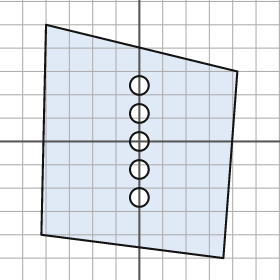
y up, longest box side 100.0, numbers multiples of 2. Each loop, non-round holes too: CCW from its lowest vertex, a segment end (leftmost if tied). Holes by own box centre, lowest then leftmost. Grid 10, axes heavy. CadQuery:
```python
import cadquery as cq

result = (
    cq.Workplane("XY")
    .moveTo(36.0, -50.0)
    .lineTo(42.0, 30.0)
    .lineTo(-40.0, 50.0)
    .lineTo(-42.0, -40.0)
    .close()
    .moveTo(0.0, -24.0)
    .circle(4.0)
    .moveTo(0.0, -12.0)
    .circle(4.0)
    .moveTo(0.0, 0.0)
    .circle(4.0)
    .moveTo(0.0, 12.0)
    .circle(4.0)
    .moveTo(0.0, 24.0)
    .circle(4.0)
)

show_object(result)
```